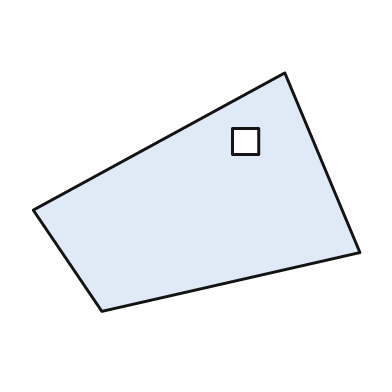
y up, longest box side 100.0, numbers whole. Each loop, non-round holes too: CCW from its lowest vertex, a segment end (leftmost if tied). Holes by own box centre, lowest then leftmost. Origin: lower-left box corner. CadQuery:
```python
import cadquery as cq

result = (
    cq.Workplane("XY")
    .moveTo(21.0, 0.0)
    .lineTo(100.0, 18.0)
    .lineTo(77.0, 73.0)
    .lineTo(0.0, 31.0)
    .close()
    .moveTo(61.0, 48.0)
    .lineTo(69.0, 48.0)
    .lineTo(69.0, 56.0)
    .lineTo(61.0, 56.0)
    .close()
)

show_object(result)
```